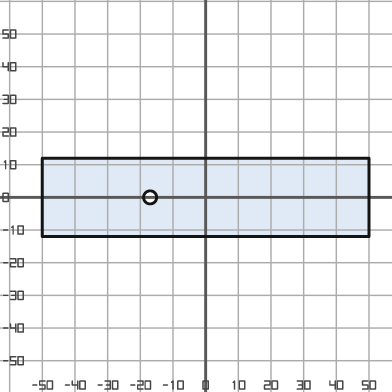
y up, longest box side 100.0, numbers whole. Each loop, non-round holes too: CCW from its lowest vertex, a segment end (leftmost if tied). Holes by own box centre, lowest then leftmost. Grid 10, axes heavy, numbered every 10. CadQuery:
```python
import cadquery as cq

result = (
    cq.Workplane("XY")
    .moveTo(-50.0, -12.0)
    .lineTo(50.0, -12.0)
    .lineTo(50.0, 12.0)
    .lineTo(-50.0, 12.0)
    .close()
    .moveTo(-17.0, 0.0)
    .circle(2.0)
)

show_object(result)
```